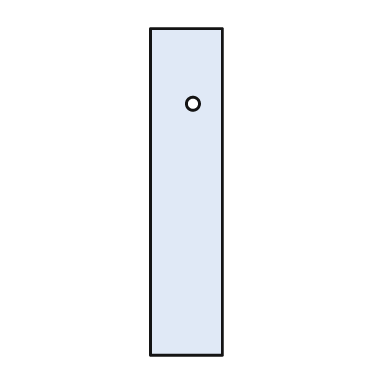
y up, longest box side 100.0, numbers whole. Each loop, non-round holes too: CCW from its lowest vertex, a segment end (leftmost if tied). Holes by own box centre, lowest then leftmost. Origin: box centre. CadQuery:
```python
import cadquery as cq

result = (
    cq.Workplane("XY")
    .moveTo(-11.0, -50.0)
    .lineTo(11.0, -50.0)
    .lineTo(11.0, 50.0)
    .lineTo(-11.0, 50.0)
    .close()
    .moveTo(2.0, 27.0)
    .circle(2.0)
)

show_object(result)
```